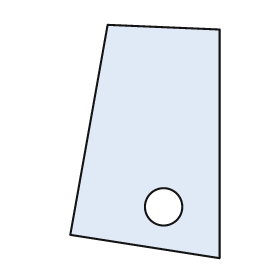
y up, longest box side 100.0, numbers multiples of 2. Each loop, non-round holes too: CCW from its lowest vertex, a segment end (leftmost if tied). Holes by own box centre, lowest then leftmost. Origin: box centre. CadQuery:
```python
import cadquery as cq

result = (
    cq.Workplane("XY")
    .moveTo(32.0, -50.0)
    .lineTo(32.0, 48.0)
    .lineTo(-16.0, 50.0)
    .lineTo(-32.0, -40.0)
    .close()
    .moveTo(8.0, -28.0)
    .circle(8.0)
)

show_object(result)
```